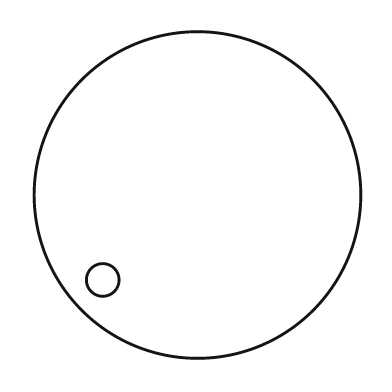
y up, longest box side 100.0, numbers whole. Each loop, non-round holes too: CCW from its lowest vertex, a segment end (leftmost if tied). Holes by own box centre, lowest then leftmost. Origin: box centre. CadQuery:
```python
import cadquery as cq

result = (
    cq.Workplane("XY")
    .moveTo(0.0, 0.0)
    .circle(50.0)
    .moveTo(-29.0, -26.0)
    .circle(5.0)
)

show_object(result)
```